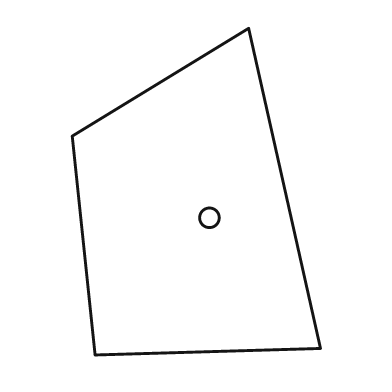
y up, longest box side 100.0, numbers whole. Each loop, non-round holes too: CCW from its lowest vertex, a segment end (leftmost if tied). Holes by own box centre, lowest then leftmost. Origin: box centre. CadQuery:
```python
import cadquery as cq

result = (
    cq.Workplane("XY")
    .moveTo(-31.0, -50.0)
    .lineTo(38.0, -48.0)
    .lineTo(16.0, 50.0)
    .lineTo(-38.0, 17.0)
    .close()
    .moveTo(4.0, -8.0)
    .circle(3.0)
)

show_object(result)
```